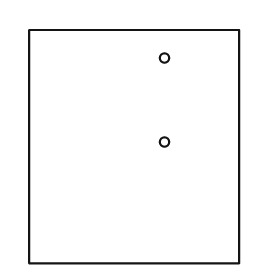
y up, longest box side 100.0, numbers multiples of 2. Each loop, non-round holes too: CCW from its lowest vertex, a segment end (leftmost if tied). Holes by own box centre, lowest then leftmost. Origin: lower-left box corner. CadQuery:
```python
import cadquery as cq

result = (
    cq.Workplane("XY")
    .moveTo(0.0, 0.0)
    .lineTo(90.0, 0.0)
    .lineTo(90.0, 100.0)
    .lineTo(0.0, 100.0)
    .close()
    .moveTo(58.0, 52.0)
    .circle(2.0)
    .moveTo(58.0, 88.0)
    .circle(2.0)
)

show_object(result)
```